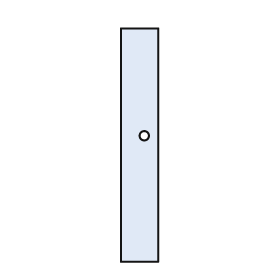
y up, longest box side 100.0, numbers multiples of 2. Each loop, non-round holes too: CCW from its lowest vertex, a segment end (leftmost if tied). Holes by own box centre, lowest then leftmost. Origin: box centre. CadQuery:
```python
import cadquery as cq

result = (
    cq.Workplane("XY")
    .moveTo(-8.0, -50.0)
    .lineTo(8.0, -50.0)
    .lineTo(8.0, 50.0)
    .lineTo(-8.0, 50.0)
    .close()
    .moveTo(2.0, 4.0)
    .circle(2.0)
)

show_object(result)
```